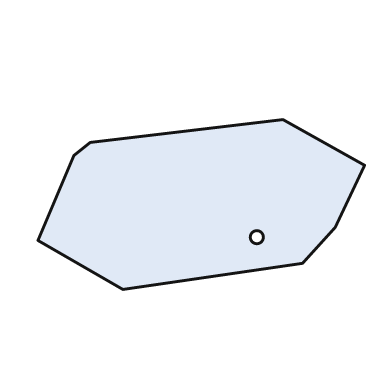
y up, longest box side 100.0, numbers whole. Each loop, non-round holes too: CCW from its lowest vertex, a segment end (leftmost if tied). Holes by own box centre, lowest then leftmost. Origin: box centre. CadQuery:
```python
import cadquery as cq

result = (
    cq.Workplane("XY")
    .moveTo(-24.0, -26.0)
    .lineTo(31.0, -18.0)
    .lineTo(41.0, -7.0)
    .lineTo(50.0, 12.0)
    .lineTo(25.0, 26.0)
    .lineTo(-34.0, 19.0)
    .lineTo(-39.0, 15.0)
    .lineTo(-50.0, -11.0)
    .close()
    .moveTo(17.0, -10.0)
    .circle(2.0)
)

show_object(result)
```